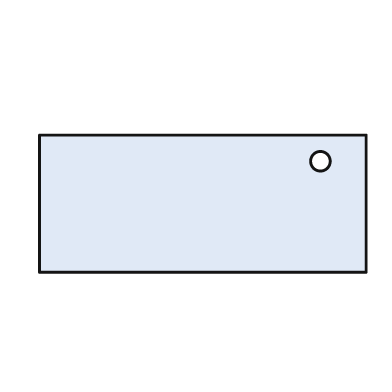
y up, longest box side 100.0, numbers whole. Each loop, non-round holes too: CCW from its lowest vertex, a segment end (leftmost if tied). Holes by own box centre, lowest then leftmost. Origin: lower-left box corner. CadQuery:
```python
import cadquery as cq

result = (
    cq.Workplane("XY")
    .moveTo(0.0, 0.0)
    .lineTo(100.0, 0.0)
    .lineTo(100.0, 42.0)
    .lineTo(0.0, 42.0)
    .close()
    .moveTo(86.0, 34.0)
    .circle(3.0)
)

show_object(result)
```